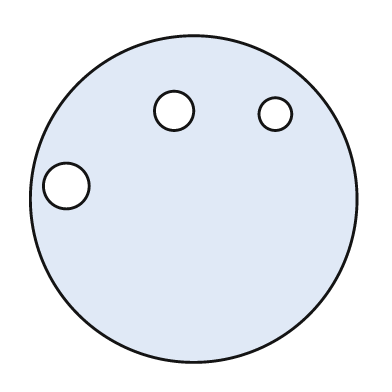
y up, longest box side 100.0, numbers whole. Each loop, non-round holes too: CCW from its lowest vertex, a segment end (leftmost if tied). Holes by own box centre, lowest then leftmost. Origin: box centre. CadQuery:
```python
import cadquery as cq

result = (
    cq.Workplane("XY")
    .moveTo(0.0, 0.0)
    .circle(50.0)
    .moveTo(-39.0, 4.0)
    .circle(7.0)
    .moveTo(25.0, 26.0)
    .circle(5.0)
    .moveTo(-6.0, 27.0)
    .circle(6.0)
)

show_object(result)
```